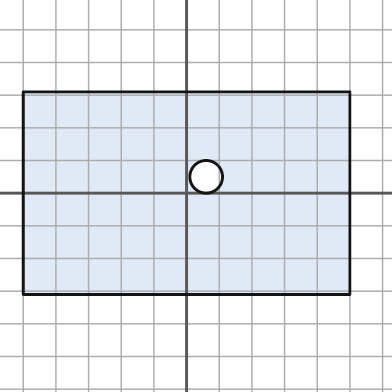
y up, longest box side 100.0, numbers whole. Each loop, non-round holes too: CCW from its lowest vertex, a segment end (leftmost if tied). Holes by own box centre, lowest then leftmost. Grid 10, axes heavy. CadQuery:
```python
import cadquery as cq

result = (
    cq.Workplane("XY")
    .moveTo(-50.0, -31.0)
    .lineTo(50.0, -31.0)
    .lineTo(50.0, 31.0)
    .lineTo(-50.0, 31.0)
    .close()
    .moveTo(6.0, 5.0)
    .circle(5.0)
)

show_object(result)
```